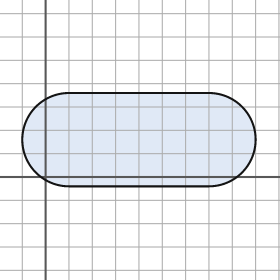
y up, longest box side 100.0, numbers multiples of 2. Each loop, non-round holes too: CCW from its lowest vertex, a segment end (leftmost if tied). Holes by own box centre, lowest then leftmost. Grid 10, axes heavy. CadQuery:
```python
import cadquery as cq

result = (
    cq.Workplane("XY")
    .moveTo(10.0, -4.0)
    .lineTo(70.0, -4.0)
    .threePointArc((90.0, 16.0), (70.0, 36.0))
    .lineTo(10.0, 36.0)
    .threePointArc((-10.0, 16.0), (10.0, -4.0))
    .close()
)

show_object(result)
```